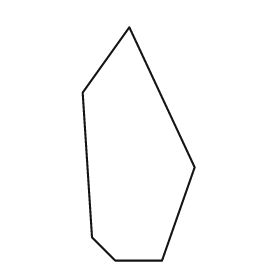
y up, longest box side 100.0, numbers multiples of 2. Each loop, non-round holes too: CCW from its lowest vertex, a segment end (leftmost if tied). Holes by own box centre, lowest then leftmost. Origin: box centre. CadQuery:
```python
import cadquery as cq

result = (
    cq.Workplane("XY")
    .moveTo(-10.0, -50.0)
    .lineTo(10.0, -50.0)
    .lineTo(24.0, -10.0)
    .lineTo(-4.0, 50.0)
    .lineTo(-24.0, 22.0)
    .lineTo(-20.0, -40.0)
    .close()
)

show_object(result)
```